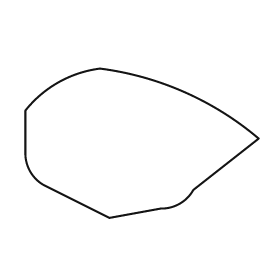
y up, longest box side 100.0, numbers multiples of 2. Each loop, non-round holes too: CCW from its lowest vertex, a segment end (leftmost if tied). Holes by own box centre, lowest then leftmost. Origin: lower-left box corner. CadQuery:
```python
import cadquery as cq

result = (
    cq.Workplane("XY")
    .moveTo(36.0, 0.0)
    .lineTo(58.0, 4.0)
    .threePointArc((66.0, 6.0), (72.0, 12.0))
    .lineTo(100.0, 34.0)
    .threePointArc((68.0, 54.0), (32.0, 64.0))
    .threePointArc((14.0, 58.0), (0.0, 46.0))
    .lineTo(0.0, 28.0)
    .threePointArc((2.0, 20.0), (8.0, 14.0))
    .close()
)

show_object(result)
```